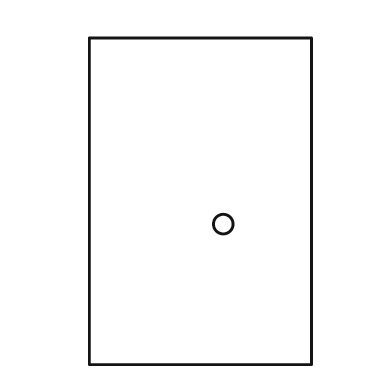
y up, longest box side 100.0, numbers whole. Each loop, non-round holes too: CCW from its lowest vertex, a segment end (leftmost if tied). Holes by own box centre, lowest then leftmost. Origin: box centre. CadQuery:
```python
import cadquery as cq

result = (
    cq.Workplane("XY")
    .moveTo(-34.0, -50.0)
    .lineTo(34.0, -50.0)
    .lineTo(34.0, 50.0)
    .lineTo(-34.0, 50.0)
    .close()
    .moveTo(7.0, -7.0)
    .circle(3.0)
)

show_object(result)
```